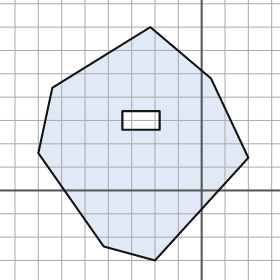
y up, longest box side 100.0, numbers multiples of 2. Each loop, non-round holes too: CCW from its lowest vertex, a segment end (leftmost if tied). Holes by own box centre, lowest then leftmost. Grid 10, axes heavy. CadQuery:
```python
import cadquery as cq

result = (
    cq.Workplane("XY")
    .moveTo(-20.0, -30.0)
    .lineTo(20.0, 14.0)
    .lineTo(4.0, 48.0)
    .lineTo(-22.0, 70.0)
    .lineTo(-64.0, 44.0)
    .lineTo(-70.0, 16.0)
    .lineTo(-42.0, -24.0)
    .close()
    .moveTo(-34.0, 26.0)
    .lineTo(-18.0, 26.0)
    .lineTo(-18.0, 34.0)
    .lineTo(-34.0, 34.0)
    .close()
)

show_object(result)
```